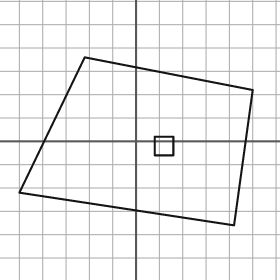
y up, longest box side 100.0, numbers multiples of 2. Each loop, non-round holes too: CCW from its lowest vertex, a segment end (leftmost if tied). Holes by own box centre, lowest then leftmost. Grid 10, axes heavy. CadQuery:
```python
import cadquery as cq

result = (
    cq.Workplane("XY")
    .moveTo(42.0, -36.0)
    .lineTo(50.0, 22.0)
    .lineTo(-22.0, 36.0)
    .lineTo(-50.0, -22.0)
    .close()
    .moveTo(8.0, -6.0)
    .lineTo(16.0, -6.0)
    .lineTo(16.0, 2.0)
    .lineTo(8.0, 2.0)
    .close()
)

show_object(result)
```